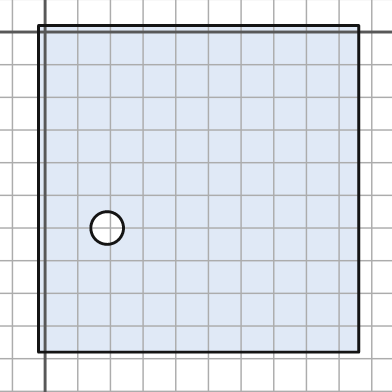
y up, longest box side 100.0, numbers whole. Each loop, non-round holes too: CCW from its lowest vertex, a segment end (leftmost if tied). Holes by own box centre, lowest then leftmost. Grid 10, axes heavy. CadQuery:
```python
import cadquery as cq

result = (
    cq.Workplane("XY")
    .moveTo(-2.0, -98.0)
    .lineTo(96.0, -98.0)
    .lineTo(96.0, 2.0)
    .lineTo(-2.0, 2.0)
    .close()
    .moveTo(19.0, -60.0)
    .circle(5.0)
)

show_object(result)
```